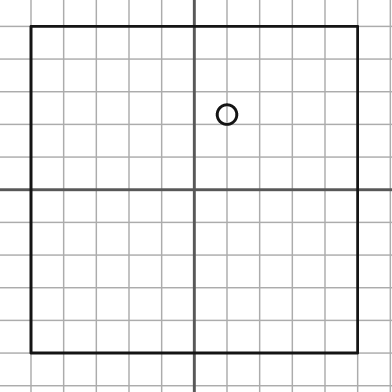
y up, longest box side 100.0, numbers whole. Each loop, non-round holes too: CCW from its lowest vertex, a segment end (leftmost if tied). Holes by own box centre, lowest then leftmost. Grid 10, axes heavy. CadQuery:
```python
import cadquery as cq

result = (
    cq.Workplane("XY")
    .moveTo(-50.0, -50.0)
    .lineTo(50.0, -50.0)
    .lineTo(50.0, 50.0)
    .lineTo(-50.0, 50.0)
    .close()
    .moveTo(10.0, 23.0)
    .circle(3.0)
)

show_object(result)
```